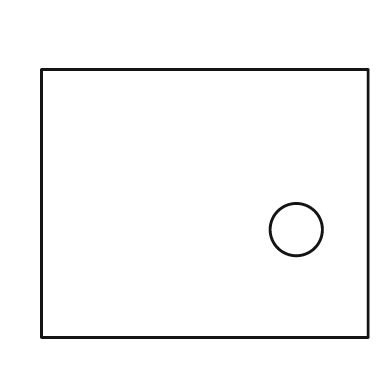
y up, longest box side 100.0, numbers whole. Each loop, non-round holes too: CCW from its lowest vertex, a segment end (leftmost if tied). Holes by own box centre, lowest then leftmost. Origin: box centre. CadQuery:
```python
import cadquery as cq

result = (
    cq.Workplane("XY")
    .moveTo(-50.0, -41.0)
    .lineTo(50.0, -41.0)
    .lineTo(50.0, 41.0)
    .lineTo(-50.0, 41.0)
    .close()
    .moveTo(28.0, -8.0)
    .circle(8.0)
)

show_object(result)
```